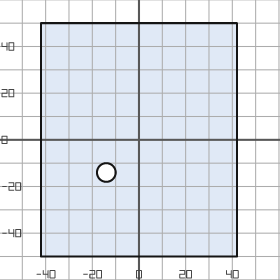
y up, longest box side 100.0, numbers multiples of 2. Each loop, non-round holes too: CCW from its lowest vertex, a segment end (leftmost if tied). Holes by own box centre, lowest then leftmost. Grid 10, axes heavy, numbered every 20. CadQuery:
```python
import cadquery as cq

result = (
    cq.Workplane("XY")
    .moveTo(-42.0, -50.0)
    .lineTo(42.0, -50.0)
    .lineTo(42.0, 50.0)
    .lineTo(-42.0, 50.0)
    .close()
    .moveTo(-14.0, -14.0)
    .circle(4.0)
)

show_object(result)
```